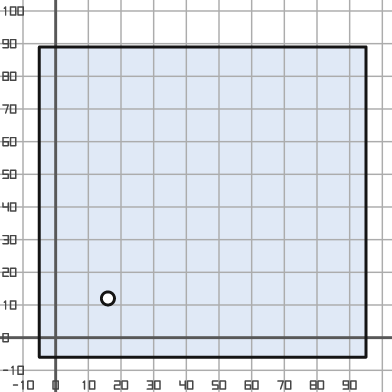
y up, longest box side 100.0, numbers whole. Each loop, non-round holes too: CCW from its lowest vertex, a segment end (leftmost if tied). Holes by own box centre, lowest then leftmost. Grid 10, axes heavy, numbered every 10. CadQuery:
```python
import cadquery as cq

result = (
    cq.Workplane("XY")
    .moveTo(-5.0, -6.0)
    .lineTo(95.0, -6.0)
    .lineTo(95.0, 89.0)
    .lineTo(-5.0, 89.0)
    .close()
    .moveTo(16.0, 12.0)
    .circle(2.0)
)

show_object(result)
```